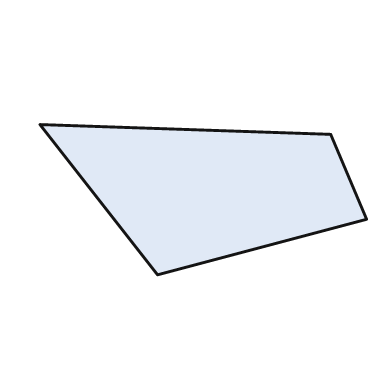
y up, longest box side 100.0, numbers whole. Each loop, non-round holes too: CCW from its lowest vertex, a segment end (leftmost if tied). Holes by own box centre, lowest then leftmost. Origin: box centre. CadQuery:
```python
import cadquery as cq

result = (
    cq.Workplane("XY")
    .moveTo(-14.0, -23.0)
    .lineTo(50.0, -6.0)
    .lineTo(39.0, 20.0)
    .lineTo(-50.0, 23.0)
    .close()
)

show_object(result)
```